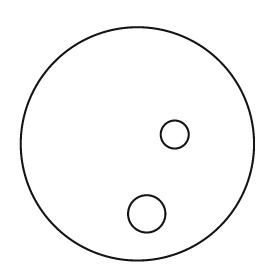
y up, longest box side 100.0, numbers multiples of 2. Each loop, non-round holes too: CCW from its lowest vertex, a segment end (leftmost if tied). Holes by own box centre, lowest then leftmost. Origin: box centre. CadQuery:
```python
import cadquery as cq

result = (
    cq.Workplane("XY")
    .moveTo(0.0, 0.0)
    .circle(50.0)
    .moveTo(4.0, -30.0)
    .circle(8.0)
    .moveTo(16.0, 4.0)
    .circle(6.0)
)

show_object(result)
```